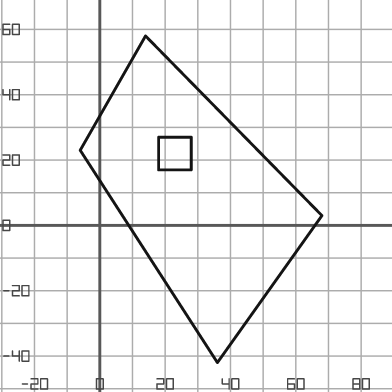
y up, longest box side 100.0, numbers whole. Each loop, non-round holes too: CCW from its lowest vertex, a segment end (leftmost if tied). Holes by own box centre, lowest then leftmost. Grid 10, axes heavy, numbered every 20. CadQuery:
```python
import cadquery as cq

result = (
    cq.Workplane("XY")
    .moveTo(36.0, -42.0)
    .lineTo(68.0, 3.0)
    .lineTo(14.0, 58.0)
    .lineTo(-6.0, 23.0)
    .close()
    .moveTo(18.0, 17.0)
    .lineTo(28.0, 17.0)
    .lineTo(28.0, 27.0)
    .lineTo(18.0, 27.0)
    .close()
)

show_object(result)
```